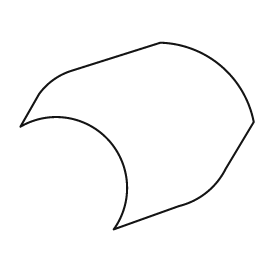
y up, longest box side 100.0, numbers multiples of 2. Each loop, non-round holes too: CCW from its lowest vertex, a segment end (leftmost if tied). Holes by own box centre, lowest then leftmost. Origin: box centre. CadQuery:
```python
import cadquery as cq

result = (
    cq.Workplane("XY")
    .moveTo(-10.0, -40.0)
    .lineTo(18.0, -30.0)
    .threePointArc((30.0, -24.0), (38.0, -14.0))
    .lineTo(50.0, 6.0)
    .threePointArc((36.0, 30.0), (10.0, 40.0))
    .lineTo(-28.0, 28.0)
    .threePointArc((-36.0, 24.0), (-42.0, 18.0))
    .lineTo(-50.0, 4.0)
    .threePointArc((-12.0, -2.0), (-10.0, -40.0))
    .close()
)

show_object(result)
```